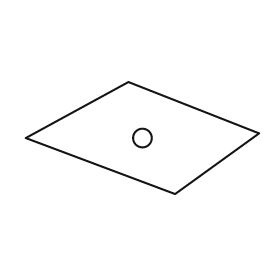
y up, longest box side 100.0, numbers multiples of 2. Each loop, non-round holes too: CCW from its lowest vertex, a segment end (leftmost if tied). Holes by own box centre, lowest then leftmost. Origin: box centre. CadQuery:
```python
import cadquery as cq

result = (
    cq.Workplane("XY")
    .moveTo(14.0, -24.0)
    .lineTo(50.0, 2.0)
    .lineTo(-6.0, 24.0)
    .lineTo(-50.0, 0.0)
    .close()
    .moveTo(0.0, 0.0)
    .circle(4.0)
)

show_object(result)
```